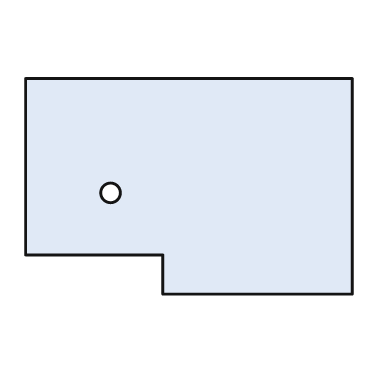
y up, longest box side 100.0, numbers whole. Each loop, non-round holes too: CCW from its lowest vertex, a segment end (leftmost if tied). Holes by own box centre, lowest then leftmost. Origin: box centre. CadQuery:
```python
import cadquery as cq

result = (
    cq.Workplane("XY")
    .moveTo(-8.0, -33.0)
    .lineTo(50.0, -33.0)
    .lineTo(50.0, 33.0)
    .lineTo(-50.0, 33.0)
    .lineTo(-50.0, -21.0)
    .lineTo(-8.0, -21.0)
    .close()
    .moveTo(-24.0, -2.0)
    .circle(3.0)
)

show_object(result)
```